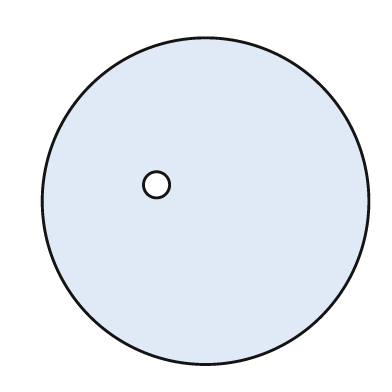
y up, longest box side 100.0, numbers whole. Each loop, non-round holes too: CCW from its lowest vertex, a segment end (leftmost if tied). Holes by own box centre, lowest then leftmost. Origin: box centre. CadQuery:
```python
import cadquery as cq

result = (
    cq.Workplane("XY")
    .moveTo(0.0, 0.0)
    .circle(50.0)
    .moveTo(-15.0, 5.0)
    .circle(4.0)
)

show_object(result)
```